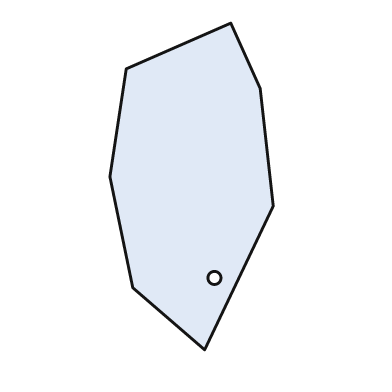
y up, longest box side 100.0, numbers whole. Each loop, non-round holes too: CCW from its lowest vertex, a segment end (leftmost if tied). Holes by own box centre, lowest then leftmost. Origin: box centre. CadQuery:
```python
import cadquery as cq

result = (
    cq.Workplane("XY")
    .moveTo(4.0, -50.0)
    .lineTo(25.0, -6.0)
    .lineTo(21.0, 30.0)
    .lineTo(12.0, 50.0)
    .lineTo(-20.0, 36.0)
    .lineTo(-25.0, 3.0)
    .lineTo(-18.0, -31.0)
    .close()
    .moveTo(7.0, -28.0)
    .circle(2.0)
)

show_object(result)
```